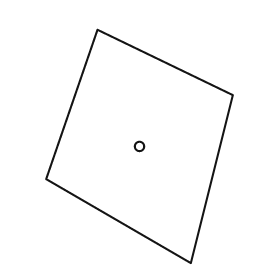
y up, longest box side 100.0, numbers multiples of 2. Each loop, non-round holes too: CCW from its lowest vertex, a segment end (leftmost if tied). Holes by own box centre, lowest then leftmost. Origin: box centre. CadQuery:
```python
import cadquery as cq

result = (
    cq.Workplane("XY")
    .moveTo(22.0, -50.0)
    .lineTo(40.0, 22.0)
    .lineTo(-18.0, 50.0)
    .lineTo(-40.0, -14.0)
    .close()
    .moveTo(0.0, 0.0)
    .circle(2.0)
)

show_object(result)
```